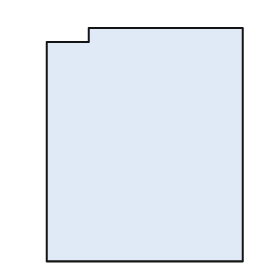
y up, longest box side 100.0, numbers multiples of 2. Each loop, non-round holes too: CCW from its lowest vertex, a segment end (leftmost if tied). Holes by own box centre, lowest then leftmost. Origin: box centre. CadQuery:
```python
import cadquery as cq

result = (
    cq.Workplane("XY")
    .moveTo(-42.0, -50.0)
    .lineTo(42.0, -50.0)
    .lineTo(42.0, 50.0)
    .lineTo(-24.0, 50.0)
    .lineTo(-24.0, 44.0)
    .lineTo(-42.0, 44.0)
    .close()
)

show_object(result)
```